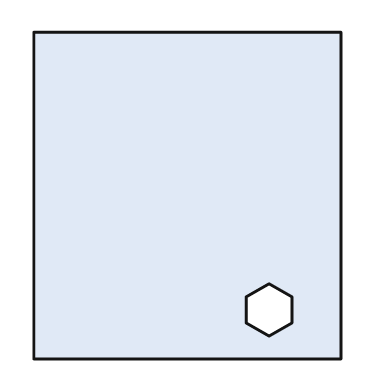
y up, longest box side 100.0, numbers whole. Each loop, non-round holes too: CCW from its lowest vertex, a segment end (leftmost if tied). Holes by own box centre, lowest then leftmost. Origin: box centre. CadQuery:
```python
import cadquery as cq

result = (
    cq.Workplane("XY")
    .moveTo(-47.0, -50.0)
    .lineTo(47.0, -50.0)
    .lineTo(47.0, 50.0)
    .lineTo(-47.0, 50.0)
    .close()
    .moveTo(25.0, -43.0)
    .lineTo(32.0, -39.0)
    .lineTo(32.0, -31.0)
    .lineTo(25.0, -27.0)
    .lineTo(18.0, -31.0)
    .lineTo(18.0, -39.0)
    .close()
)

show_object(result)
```